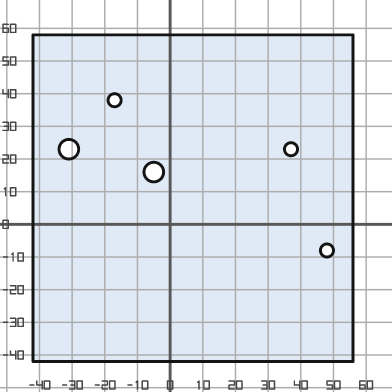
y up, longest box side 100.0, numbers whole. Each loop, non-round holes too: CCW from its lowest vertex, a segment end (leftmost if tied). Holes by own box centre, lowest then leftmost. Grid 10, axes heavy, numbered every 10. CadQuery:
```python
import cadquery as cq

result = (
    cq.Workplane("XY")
    .moveTo(-42.0, -42.0)
    .lineTo(56.0, -42.0)
    .lineTo(56.0, 58.0)
    .lineTo(-42.0, 58.0)
    .close()
    .moveTo(48.0, -8.0)
    .circle(2.0)
    .moveTo(-5.0, 16.0)
    .circle(3.0)
    .moveTo(-31.0, 23.0)
    .circle(3.0)
    .moveTo(37.0, 23.0)
    .circle(2.0)
    .moveTo(-17.0, 38.0)
    .circle(2.0)
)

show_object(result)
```